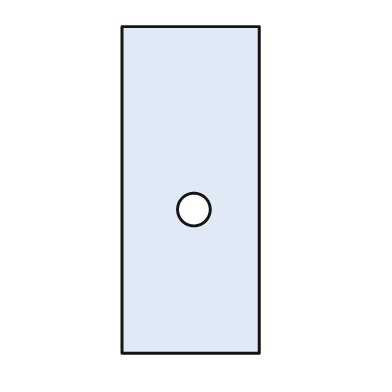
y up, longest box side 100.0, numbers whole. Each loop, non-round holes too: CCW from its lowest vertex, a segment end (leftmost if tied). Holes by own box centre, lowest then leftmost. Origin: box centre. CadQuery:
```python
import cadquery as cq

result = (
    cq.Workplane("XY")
    .moveTo(-21.0, -50.0)
    .lineTo(21.0, -50.0)
    .lineTo(21.0, 50.0)
    .lineTo(-21.0, 50.0)
    .close()
    .moveTo(1.0, -6.0)
    .circle(5.0)
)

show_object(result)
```